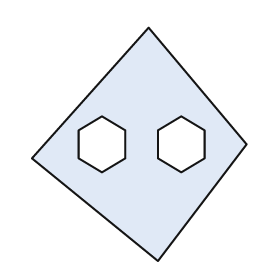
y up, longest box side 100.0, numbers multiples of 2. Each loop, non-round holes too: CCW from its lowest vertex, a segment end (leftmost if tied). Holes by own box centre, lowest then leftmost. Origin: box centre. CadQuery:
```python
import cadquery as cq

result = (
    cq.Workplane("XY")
    .moveTo(8.0, -50.0)
    .lineTo(46.0, 0.0)
    .lineTo(4.0, 50.0)
    .lineTo(-46.0, -6.0)
    .close()
    .moveTo(-16.0, -12.0)
    .lineTo(-6.0, -6.0)
    .lineTo(-6.0, 6.0)
    .lineTo(-16.0, 12.0)
    .lineTo(-26.0, 6.0)
    .lineTo(-26.0, -6.0)
    .close()
    .moveTo(18.0, -12.0)
    .lineTo(28.0, -6.0)
    .lineTo(28.0, 6.0)
    .lineTo(18.0, 12.0)
    .lineTo(8.0, 6.0)
    .lineTo(8.0, -6.0)
    .close()
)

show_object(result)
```